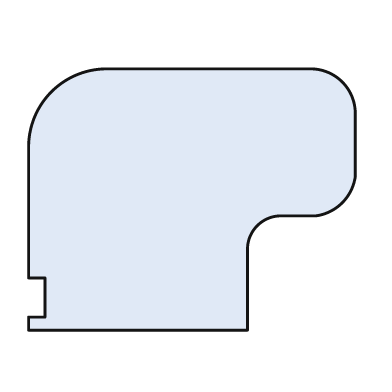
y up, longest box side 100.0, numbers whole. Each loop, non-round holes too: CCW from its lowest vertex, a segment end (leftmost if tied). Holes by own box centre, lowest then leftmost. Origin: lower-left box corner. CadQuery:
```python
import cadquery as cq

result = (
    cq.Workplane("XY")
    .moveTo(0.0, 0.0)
    .lineTo(67.0, 0.0)
    .lineTo(67.0, 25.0)
    .threePointArc((70.0, 32.0), (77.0, 35.0))
    .lineTo(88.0, 35.0)
    .threePointArc((96.0, 39.0), (100.0, 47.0))
    .lineTo(100.0, 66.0)
    .threePointArc((96.0, 76.0), (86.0, 80.0))
    .lineTo(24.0, 80.0)
    .threePointArc((7.0, 73.0), (0.0, 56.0))
    .lineTo(0.0, 16.0)
    .lineTo(5.0, 16.0)
    .lineTo(5.0, 4.0)
    .lineTo(0.0, 4.0)
    .close()
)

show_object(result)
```